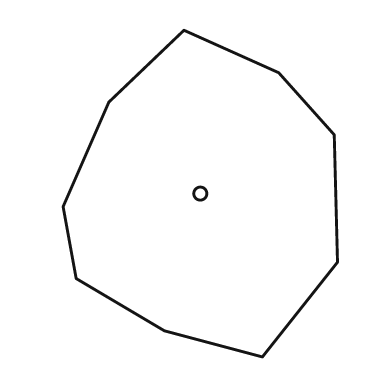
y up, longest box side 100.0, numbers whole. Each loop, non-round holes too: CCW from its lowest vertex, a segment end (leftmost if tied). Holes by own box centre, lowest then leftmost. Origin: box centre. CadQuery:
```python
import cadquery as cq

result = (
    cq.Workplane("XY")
    .moveTo(19.0, -50.0)
    .lineTo(42.0, -21.0)
    .lineTo(41.0, 18.0)
    .lineTo(24.0, 37.0)
    .lineTo(-5.0, 50.0)
    .lineTo(-28.0, 28.0)
    .lineTo(-42.0, -4.0)
    .lineTo(-38.0, -26.0)
    .lineTo(-11.0, -42.0)
    .close()
    .moveTo(0.0, 0.0)
    .circle(2.0)
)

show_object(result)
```